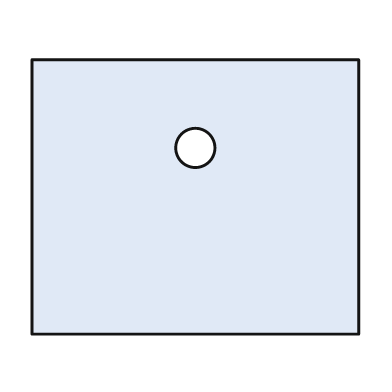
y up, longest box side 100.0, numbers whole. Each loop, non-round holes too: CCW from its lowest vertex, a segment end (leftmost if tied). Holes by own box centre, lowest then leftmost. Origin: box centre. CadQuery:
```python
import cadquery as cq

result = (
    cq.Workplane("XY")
    .moveTo(-50.0, -42.0)
    .lineTo(50.0, -42.0)
    .lineTo(50.0, 42.0)
    .lineTo(-50.0, 42.0)
    .close()
    .moveTo(0.0, 15.0)
    .circle(6.0)
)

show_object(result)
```